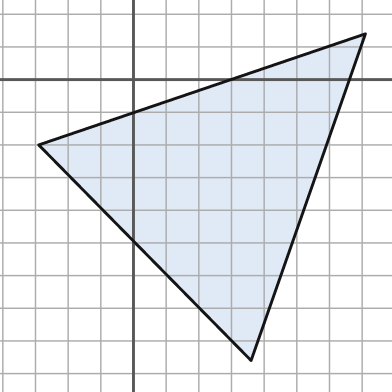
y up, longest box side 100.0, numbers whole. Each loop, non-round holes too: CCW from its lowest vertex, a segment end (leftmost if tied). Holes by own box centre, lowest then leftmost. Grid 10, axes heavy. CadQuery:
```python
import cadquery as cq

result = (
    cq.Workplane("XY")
    .moveTo(36.0, -86.0)
    .lineTo(71.0, 14.0)
    .lineTo(-29.0, -20.0)
    .close()
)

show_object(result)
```